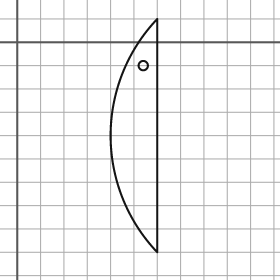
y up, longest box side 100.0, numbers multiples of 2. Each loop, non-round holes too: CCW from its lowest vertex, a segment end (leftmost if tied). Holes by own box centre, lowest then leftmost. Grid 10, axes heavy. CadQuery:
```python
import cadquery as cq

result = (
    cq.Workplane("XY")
    .moveTo(60.0, -90.0)
    .lineTo(60.0, 10.0)
    .threePointArc((40.0, -40.0), (60.0, -90.0))
    .close()
    .moveTo(54.0, -10.0)
    .circle(2.0)
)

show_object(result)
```